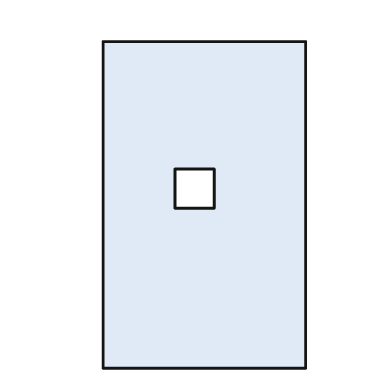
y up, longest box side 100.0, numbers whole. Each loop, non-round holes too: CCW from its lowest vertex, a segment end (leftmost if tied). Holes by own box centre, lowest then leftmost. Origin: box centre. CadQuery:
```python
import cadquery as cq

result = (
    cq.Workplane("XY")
    .moveTo(-31.0, -50.0)
    .lineTo(31.0, -50.0)
    .lineTo(31.0, 50.0)
    .lineTo(-31.0, 50.0)
    .close()
    .moveTo(-9.0, -1.0)
    .lineTo(3.0, -1.0)
    .lineTo(3.0, 11.0)
    .lineTo(-9.0, 11.0)
    .close()
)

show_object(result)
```